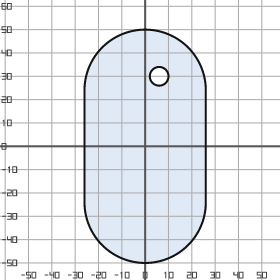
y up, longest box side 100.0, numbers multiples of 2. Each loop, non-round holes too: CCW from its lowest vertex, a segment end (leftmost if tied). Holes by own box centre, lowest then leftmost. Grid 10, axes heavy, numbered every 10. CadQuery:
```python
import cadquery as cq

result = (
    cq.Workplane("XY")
    .moveTo(-26.0, -24.0)
    .threePointArc((0.0, -50.0), (26.0, -24.0))
    .lineTo(26.0, 24.0)
    .threePointArc((0.0, 50.0), (-26.0, 24.0))
    .close()
    .moveTo(6.0, 30.0)
    .circle(4.0)
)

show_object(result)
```